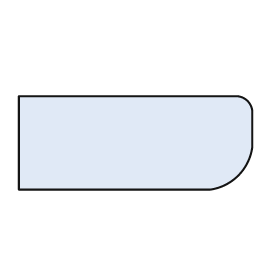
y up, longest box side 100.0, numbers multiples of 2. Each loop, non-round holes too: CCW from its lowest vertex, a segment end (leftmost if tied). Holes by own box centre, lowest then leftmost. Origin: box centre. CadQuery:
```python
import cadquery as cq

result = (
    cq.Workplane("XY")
    .moveTo(-50.0, -20.0)
    .lineTo(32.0, -20.0)
    .threePointArc((44.0, -14.0), (50.0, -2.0))
    .lineTo(50.0, 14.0)
    .threePointArc((48.0, 18.0), (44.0, 20.0))
    .lineTo(-50.0, 20.0)
    .close()
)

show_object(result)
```